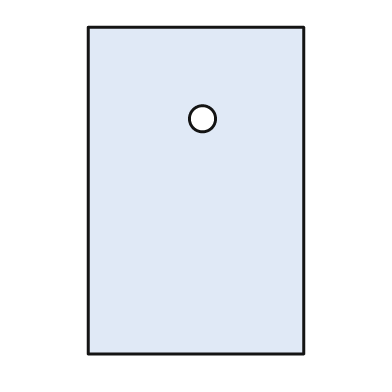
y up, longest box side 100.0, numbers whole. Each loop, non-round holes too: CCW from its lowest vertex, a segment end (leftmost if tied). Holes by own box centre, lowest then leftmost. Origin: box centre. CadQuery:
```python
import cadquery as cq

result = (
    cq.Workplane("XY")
    .moveTo(-33.0, -50.0)
    .lineTo(33.0, -50.0)
    .lineTo(33.0, 50.0)
    .lineTo(-33.0, 50.0)
    .close()
    .moveTo(2.0, 22.0)
    .circle(4.0)
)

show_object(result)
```